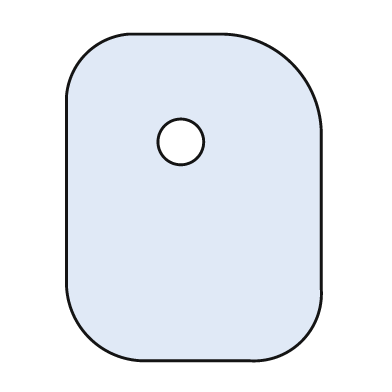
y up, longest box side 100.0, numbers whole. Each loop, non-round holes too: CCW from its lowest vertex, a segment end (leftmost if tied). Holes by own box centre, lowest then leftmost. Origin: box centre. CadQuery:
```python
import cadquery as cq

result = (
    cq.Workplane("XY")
    .moveTo(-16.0, -50.0)
    .lineTo(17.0, -50.0)
    .threePointArc((33.0, -44.0), (39.0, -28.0))
    .lineTo(39.0, 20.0)
    .threePointArc((30.0, 41.0), (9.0, 50.0))
    .lineTo(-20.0, 50.0)
    .threePointArc((-33.0, 44.0), (-39.0, 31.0))
    .lineTo(-39.0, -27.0)
    .threePointArc((-32.0, -43.0), (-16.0, -50.0))
    .close()
    .moveTo(-4.0, 17.0)
    .circle(7.0)
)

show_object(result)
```